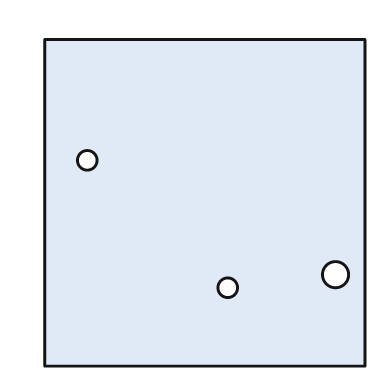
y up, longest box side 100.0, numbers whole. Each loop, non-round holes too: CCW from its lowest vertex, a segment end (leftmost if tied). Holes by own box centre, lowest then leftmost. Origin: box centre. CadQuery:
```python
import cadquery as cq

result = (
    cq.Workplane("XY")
    .moveTo(-49.0, -50.0)
    .lineTo(49.0, -50.0)
    .lineTo(49.0, 50.0)
    .lineTo(-49.0, 50.0)
    .close()
    .moveTo(7.0, -26.0)
    .circle(3.0)
    .moveTo(40.0, -22.0)
    .circle(4.0)
    .moveTo(-36.0, 13.0)
    .circle(3.0)
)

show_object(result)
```